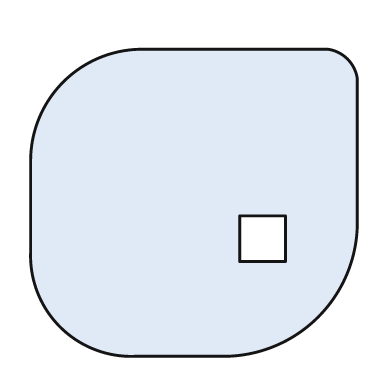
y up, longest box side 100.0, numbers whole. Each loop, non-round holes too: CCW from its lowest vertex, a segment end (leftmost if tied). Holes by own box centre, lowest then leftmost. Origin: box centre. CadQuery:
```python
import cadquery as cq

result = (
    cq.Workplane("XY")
    .moveTo(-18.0, -47.0)
    .lineTo(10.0, -47.0)
    .threePointArc((38.0, -35.0), (50.0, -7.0))
    .lineTo(50.0, 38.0)
    .threePointArc((47.0, 44.0), (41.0, 47.0))
    .lineTo(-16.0, 47.0)
    .threePointArc((-40.0, 37.0), (-50.0, 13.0))
    .lineTo(-50.0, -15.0)
    .threePointArc((-41.0, -38.0), (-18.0, -47.0))
    .close()
    .moveTo(14.0, -18.0)
    .lineTo(28.0, -18.0)
    .lineTo(28.0, -4.0)
    .lineTo(14.0, -4.0)
    .close()
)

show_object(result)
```